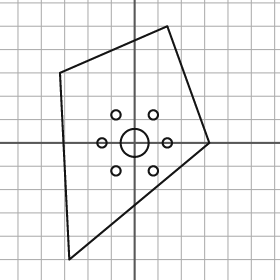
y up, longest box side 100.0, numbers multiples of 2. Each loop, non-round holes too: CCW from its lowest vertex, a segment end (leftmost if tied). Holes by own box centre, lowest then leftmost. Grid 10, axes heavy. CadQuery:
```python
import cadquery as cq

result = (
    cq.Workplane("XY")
    .moveTo(-28.0, -50.0)
    .lineTo(32.0, 0.0)
    .lineTo(14.0, 50.0)
    .lineTo(-32.0, 30.0)
    .close()
    .moveTo(-8.0, -12.0)
    .circle(2.0)
    .moveTo(8.0, -12.0)
    .circle(2.0)
    .moveTo(-14.0, 0.0)
    .circle(2.0)
    .moveTo(0.0, 0.0)
    .circle(6.0)
    .moveTo(14.0, 0.0)
    .circle(2.0)
    .moveTo(-8.0, 12.0)
    .circle(2.0)
    .moveTo(8.0, 12.0)
    .circle(2.0)
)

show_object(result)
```